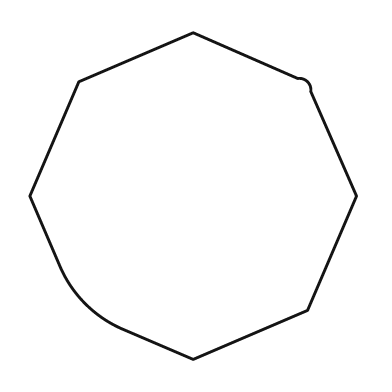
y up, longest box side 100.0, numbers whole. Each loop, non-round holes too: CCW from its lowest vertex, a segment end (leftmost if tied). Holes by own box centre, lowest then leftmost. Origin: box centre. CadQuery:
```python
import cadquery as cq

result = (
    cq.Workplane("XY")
    .moveTo(0.0, -50.0)
    .lineTo(35.0, -35.0)
    .lineTo(50.0, 0.0)
    .lineTo(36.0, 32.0)
    .threePointArc((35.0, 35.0), (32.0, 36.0))
    .lineTo(0.0, 50.0)
    .lineTo(-35.0, 35.0)
    .lineTo(-50.0, 0.0)
    .lineTo(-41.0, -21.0)
    .threePointArc((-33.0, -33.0), (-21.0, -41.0))
    .close()
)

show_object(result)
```